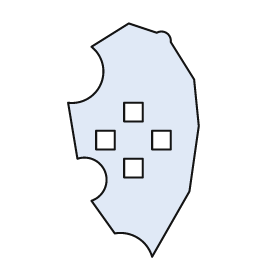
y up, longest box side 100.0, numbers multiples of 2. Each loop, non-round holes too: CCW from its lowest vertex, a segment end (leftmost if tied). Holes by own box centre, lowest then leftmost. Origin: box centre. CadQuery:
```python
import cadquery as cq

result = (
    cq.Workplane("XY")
    .moveTo(8.0, -50.0)
    .lineTo(24.0, -22.0)
    .lineTo(28.0, 6.0)
    .lineTo(26.0, 26.0)
    .lineTo(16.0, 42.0)
    .threePointArc((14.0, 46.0), (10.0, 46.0))
    .lineTo(-2.0, 50.0)
    .lineTo(-18.0, 40.0)
    .threePointArc((-14.0, 24.0), (-28.0, 16.0))
    .lineTo(-24.0, -8.0)
    .threePointArc((-12.0, -14.0), (-18.0, -26.0))
    .lineTo(-8.0, -40.0)
    .threePointArc((2.0, -42.0), (8.0, -50.0))
    .close()
    .moveTo(-4.0, -16.0)
    .lineTo(4.0, -16.0)
    .lineTo(4.0, -8.0)
    .lineTo(-4.0, -8.0)
    .close()
    .moveTo(-16.0, -4.0)
    .lineTo(-8.0, -4.0)
    .lineTo(-8.0, 4.0)
    .lineTo(-16.0, 4.0)
    .close()
    .moveTo(8.0, -4.0)
    .lineTo(16.0, -4.0)
    .lineTo(16.0, 4.0)
    .lineTo(8.0, 4.0)
    .close()
    .moveTo(-4.0, 8.0)
    .lineTo(4.0, 8.0)
    .lineTo(4.0, 16.0)
    .lineTo(-4.0, 16.0)
    .close()
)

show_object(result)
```